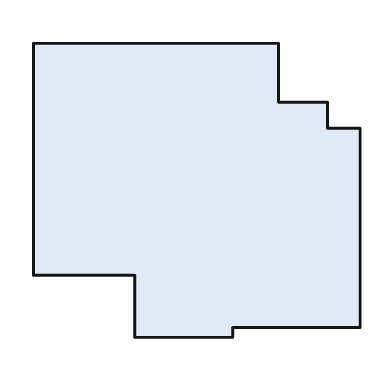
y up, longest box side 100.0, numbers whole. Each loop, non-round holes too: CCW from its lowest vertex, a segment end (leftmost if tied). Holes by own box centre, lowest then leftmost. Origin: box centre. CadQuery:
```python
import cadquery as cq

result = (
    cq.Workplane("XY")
    .moveTo(-19.0, -45.0)
    .lineTo(11.0, -45.0)
    .lineTo(11.0, -42.0)
    .lineTo(50.0, -42.0)
    .lineTo(50.0, 19.0)
    .lineTo(40.0, 19.0)
    .lineTo(40.0, 27.0)
    .lineTo(25.0, 27.0)
    .lineTo(25.0, 45.0)
    .lineTo(-50.0, 45.0)
    .lineTo(-50.0, -26.0)
    .lineTo(-19.0, -26.0)
    .close()
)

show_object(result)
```